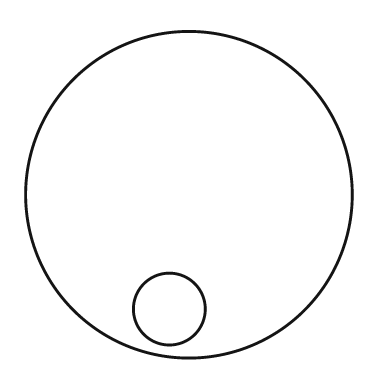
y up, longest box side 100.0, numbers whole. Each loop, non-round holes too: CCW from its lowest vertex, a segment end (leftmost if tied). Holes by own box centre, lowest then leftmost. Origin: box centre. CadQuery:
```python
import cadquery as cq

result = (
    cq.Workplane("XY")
    .moveTo(0.0, 0.0)
    .circle(50.0)
    .moveTo(-6.0, -35.0)
    .circle(11.0)
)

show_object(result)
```